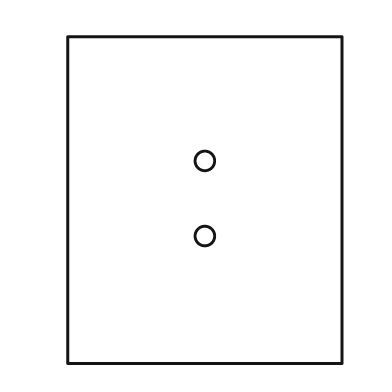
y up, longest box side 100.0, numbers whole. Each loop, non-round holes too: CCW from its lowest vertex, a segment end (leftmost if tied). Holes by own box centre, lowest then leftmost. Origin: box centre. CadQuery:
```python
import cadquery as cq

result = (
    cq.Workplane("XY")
    .moveTo(-42.0, -50.0)
    .lineTo(42.0, -50.0)
    .lineTo(42.0, 50.0)
    .lineTo(-42.0, 50.0)
    .close()
    .moveTo(0.0, -11.0)
    .circle(3.0)
    .moveTo(0.0, 12.0)
    .circle(3.0)
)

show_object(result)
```